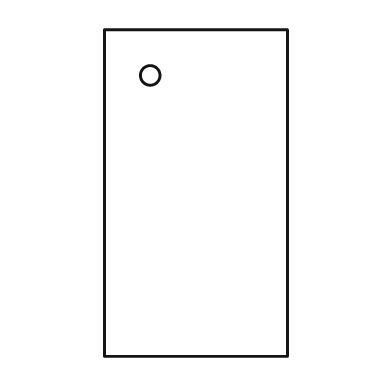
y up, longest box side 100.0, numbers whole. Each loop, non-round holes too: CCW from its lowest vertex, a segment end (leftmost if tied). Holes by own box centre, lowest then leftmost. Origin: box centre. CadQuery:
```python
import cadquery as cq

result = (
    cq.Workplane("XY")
    .moveTo(-28.0, -50.0)
    .lineTo(28.0, -50.0)
    .lineTo(28.0, 50.0)
    .lineTo(-28.0, 50.0)
    .close()
    .moveTo(-14.0, 36.0)
    .circle(3.0)
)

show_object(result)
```